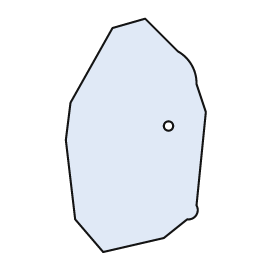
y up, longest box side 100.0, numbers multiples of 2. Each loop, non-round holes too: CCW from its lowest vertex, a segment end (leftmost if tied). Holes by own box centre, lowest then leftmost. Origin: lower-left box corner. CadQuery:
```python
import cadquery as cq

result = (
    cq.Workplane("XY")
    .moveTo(16.0, 0.0)
    .lineTo(42.0, 6.0)
    .lineTo(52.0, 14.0)
    .threePointArc((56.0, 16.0), (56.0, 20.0))
    .lineTo(60.0, 60.0)
    .lineTo(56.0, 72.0)
    .threePointArc((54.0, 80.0), (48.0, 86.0))
    .lineTo(34.0, 100.0)
    .lineTo(20.0, 96.0)
    .lineTo(2.0, 64.0)
    .lineTo(0.0, 48.0)
    .lineTo(4.0, 14.0)
    .close()
    .moveTo(44.0, 54.0)
    .circle(2.0)
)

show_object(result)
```